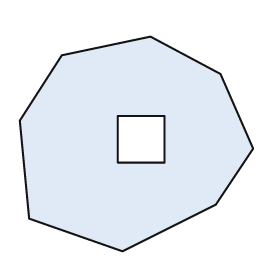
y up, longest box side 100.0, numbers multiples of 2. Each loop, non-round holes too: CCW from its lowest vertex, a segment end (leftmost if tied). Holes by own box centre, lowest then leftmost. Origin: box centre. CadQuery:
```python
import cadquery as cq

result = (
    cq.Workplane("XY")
    .moveTo(-6.0, -46.0)
    .lineTo(34.0, -26.0)
    .lineTo(50.0, -2.0)
    .lineTo(36.0, 30.0)
    .lineTo(6.0, 46.0)
    .lineTo(-32.0, 38.0)
    .lineTo(-50.0, 10.0)
    .lineTo(-46.0, -32.0)
    .close()
    .moveTo(-8.0, -8.0)
    .lineTo(12.0, -8.0)
    .lineTo(12.0, 12.0)
    .lineTo(-8.0, 12.0)
    .close()
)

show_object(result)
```